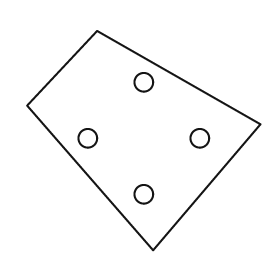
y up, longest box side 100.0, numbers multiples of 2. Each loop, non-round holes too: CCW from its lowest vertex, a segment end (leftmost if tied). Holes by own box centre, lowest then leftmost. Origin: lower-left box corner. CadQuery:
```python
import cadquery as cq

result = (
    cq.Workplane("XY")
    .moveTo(54.0, 0.0)
    .lineTo(100.0, 54.0)
    .lineTo(30.0, 94.0)
    .lineTo(0.0, 62.0)
    .close()
    .moveTo(50.0, 24.0)
    .circle(4.0)
    .moveTo(26.0, 48.0)
    .circle(4.0)
    .moveTo(74.0, 48.0)
    .circle(4.0)
    .moveTo(50.0, 72.0)
    .circle(4.0)
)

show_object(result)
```